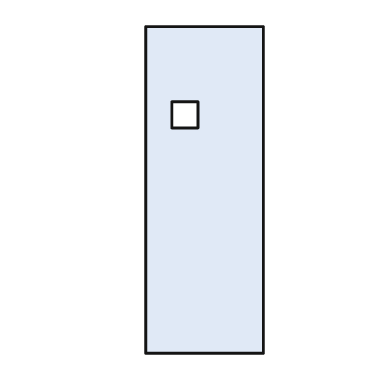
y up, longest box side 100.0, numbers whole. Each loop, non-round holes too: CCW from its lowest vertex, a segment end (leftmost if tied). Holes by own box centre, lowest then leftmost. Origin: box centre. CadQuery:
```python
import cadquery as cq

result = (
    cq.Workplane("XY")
    .moveTo(-18.0, -50.0)
    .lineTo(18.0, -50.0)
    .lineTo(18.0, 50.0)
    .lineTo(-18.0, 50.0)
    .close()
    .moveTo(-10.0, 19.0)
    .lineTo(-2.0, 19.0)
    .lineTo(-2.0, 27.0)
    .lineTo(-10.0, 27.0)
    .close()
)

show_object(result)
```